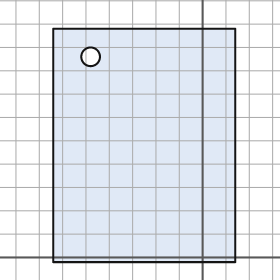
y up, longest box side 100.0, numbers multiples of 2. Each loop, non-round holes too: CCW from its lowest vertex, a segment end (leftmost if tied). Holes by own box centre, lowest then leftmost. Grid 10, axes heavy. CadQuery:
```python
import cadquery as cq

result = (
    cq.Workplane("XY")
    .moveTo(-64.0, -2.0)
    .lineTo(14.0, -2.0)
    .lineTo(14.0, 98.0)
    .lineTo(-64.0, 98.0)
    .close()
    .moveTo(-48.0, 86.0)
    .circle(4.0)
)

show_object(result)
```